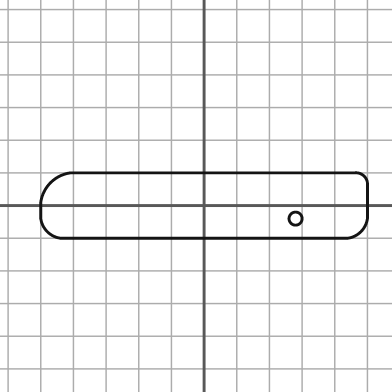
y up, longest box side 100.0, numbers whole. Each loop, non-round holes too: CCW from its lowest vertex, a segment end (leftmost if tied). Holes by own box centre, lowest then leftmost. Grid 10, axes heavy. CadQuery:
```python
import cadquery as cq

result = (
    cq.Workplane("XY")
    .moveTo(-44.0, -10.0)
    .lineTo(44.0, -10.0)
    .threePointArc((48.0, -8.0), (50.0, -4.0))
    .lineTo(50.0, 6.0)
    .threePointArc((49.0, 9.0), (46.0, 10.0))
    .lineTo(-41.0, 10.0)
    .threePointArc((-47.0, 7.0), (-50.0, 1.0))
    .lineTo(-50.0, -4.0)
    .threePointArc((-48.0, -8.0), (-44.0, -10.0))
    .close()
    .moveTo(28.0, -4.0)
    .circle(2.0)
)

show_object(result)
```